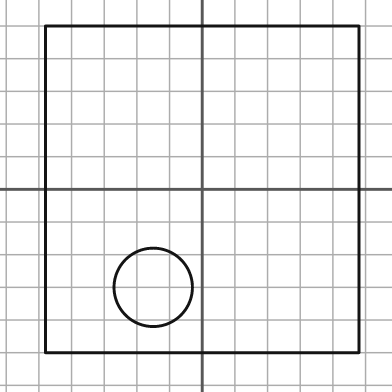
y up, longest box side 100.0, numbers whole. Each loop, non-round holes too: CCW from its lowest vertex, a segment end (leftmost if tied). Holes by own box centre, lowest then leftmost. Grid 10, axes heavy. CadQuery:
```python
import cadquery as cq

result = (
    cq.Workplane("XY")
    .moveTo(-48.0, -50.0)
    .lineTo(48.0, -50.0)
    .lineTo(48.0, 50.0)
    .lineTo(-48.0, 50.0)
    .close()
    .moveTo(-15.0, -30.0)
    .circle(12.0)
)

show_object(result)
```